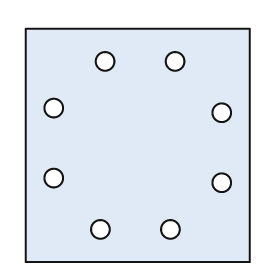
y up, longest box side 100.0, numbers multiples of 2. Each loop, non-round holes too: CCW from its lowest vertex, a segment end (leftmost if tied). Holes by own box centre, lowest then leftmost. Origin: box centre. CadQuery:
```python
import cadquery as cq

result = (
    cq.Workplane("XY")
    .moveTo(-48.0, -50.0)
    .lineTo(48.0, -50.0)
    .lineTo(48.0, 50.0)
    .lineTo(-48.0, 50.0)
    .close()
    .moveTo(-16.0, -36.0)
    .circle(4.0)
    .moveTo(14.0, -36.0)
    .circle(4.0)
    .moveTo(36.0, -16.0)
    .circle(4.0)
    .moveTo(-36.0, -14.0)
    .circle(4.0)
    .moveTo(36.0, 14.0)
    .circle(4.0)
    .moveTo(-36.0, 16.0)
    .circle(4.0)
    .moveTo(-14.0, 36.0)
    .circle(4.0)
    .moveTo(16.0, 36.0)
    .circle(4.0)
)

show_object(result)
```